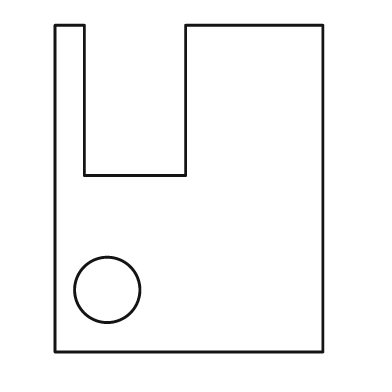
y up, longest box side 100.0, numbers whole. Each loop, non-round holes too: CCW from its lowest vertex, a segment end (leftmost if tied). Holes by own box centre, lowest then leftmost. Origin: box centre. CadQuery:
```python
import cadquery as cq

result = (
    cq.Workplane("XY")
    .moveTo(-41.0, -50.0)
    .lineTo(41.0, -50.0)
    .lineTo(41.0, 50.0)
    .lineTo(-1.0, 50.0)
    .lineTo(-1.0, 4.0)
    .lineTo(-32.0, 4.0)
    .lineTo(-32.0, 50.0)
    .lineTo(-41.0, 50.0)
    .close()
    .moveTo(-25.0, -31.0)
    .circle(10.0)
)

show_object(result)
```